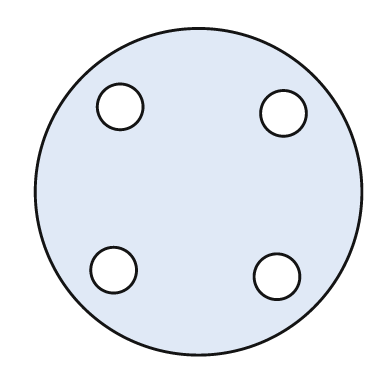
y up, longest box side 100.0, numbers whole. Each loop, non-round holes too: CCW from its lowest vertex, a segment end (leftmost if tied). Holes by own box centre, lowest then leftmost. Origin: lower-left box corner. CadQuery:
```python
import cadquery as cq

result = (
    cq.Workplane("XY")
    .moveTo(50.0, 50.0)
    .circle(50.0)
    .moveTo(74.0, 24.0)
    .circle(7.0)
    .moveTo(24.0, 26.0)
    .circle(7.0)
    .moveTo(76.0, 74.0)
    .circle(7.0)
    .moveTo(26.0, 76.0)
    .circle(7.0)
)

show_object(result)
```